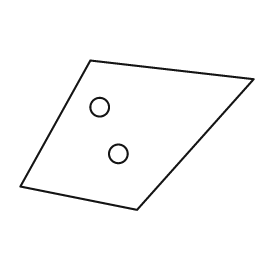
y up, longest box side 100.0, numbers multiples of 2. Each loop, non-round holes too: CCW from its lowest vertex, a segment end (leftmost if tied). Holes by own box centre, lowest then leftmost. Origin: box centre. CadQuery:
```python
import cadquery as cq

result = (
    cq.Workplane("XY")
    .moveTo(0.0, -32.0)
    .lineTo(50.0, 24.0)
    .lineTo(-20.0, 32.0)
    .lineTo(-50.0, -22.0)
    .close()
    .moveTo(-8.0, -8.0)
    .circle(4.0)
    .moveTo(-16.0, 12.0)
    .circle(4.0)
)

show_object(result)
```